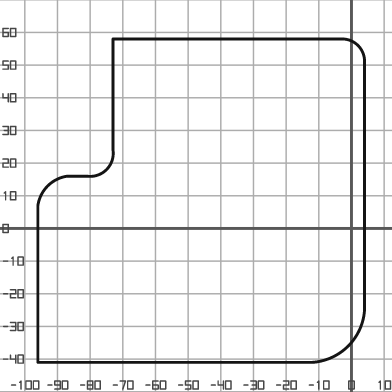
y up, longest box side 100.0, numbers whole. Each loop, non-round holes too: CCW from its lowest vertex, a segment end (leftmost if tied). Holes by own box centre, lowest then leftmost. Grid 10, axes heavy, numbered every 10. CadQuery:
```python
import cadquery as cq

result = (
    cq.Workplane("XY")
    .moveTo(-96.0, -41.0)
    .lineTo(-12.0, -41.0)
    .threePointArc((-1.0, -36.0), (4.0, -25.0))
    .lineTo(4.0, 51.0)
    .threePointArc((2.0, 56.0), (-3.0, 58.0))
    .lineTo(-73.0, 58.0)
    .lineTo(-73.0, 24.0)
    .threePointArc((-75.0, 18.0), (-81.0, 16.0))
    .lineTo(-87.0, 16.0)
    .threePointArc((-93.0, 13.0), (-96.0, 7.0))
    .close()
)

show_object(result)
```